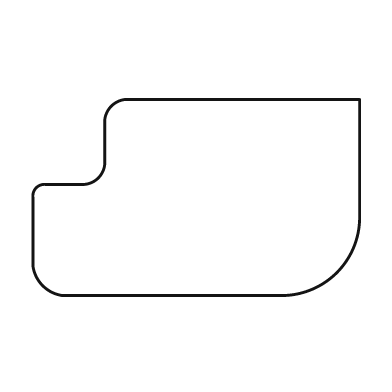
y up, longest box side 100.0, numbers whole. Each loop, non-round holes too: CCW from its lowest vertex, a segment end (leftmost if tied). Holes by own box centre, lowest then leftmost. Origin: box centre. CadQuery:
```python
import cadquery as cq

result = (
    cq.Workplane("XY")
    .moveTo(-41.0, -30.0)
    .lineTo(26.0, -30.0)
    .threePointArc((43.0, -23.0), (50.0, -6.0))
    .lineTo(50.0, 30.0)
    .lineTo(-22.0, 30.0)
    .threePointArc((-26.0, 28.0), (-28.0, 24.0))
    .lineTo(-28.0, 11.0)
    .threePointArc((-30.0, 6.0), (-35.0, 4.0))
    .lineTo(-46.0, 4.0)
    .threePointArc((-49.0, 3.0), (-50.0, 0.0))
    .lineTo(-50.0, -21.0)
    .threePointArc((-47.0, -27.0), (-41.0, -30.0))
    .close()
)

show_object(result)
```